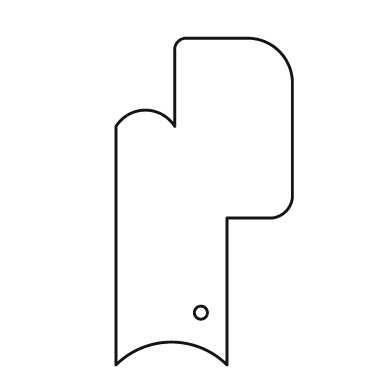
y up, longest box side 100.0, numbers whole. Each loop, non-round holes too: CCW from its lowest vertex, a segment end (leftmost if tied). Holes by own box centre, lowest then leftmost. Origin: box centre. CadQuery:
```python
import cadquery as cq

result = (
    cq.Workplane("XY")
    .moveTo(-27.0, -50.0)
    .threePointArc((-10.0, -43.0), (7.0, -50.0))
    .lineTo(7.0, -5.0)
    .lineTo(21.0, -5.0)
    .threePointArc((25.0, -3.0), (27.0, 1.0))
    .lineTo(27.0, 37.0)
    .threePointArc((23.0, 46.0), (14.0, 50.0))
    .lineTo(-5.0, 50.0)
    .threePointArc((-8.0, 49.0), (-9.0, 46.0))
    .lineTo(-9.0, 23.0)
    .threePointArc((-18.0, 28.0), (-27.0, 23.0))
    .close()
    .moveTo(-1.0, -34.0)
    .circle(2.0)
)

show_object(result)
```